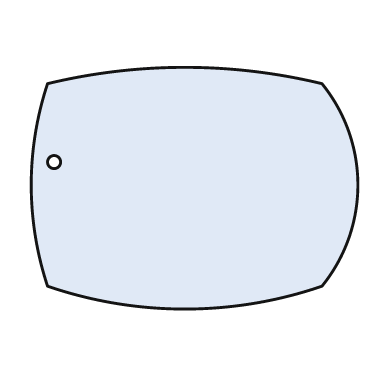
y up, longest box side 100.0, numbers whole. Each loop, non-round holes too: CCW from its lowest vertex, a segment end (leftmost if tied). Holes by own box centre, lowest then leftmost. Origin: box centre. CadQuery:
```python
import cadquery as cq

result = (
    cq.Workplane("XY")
    .moveTo(-45.0, -30.0)
    .threePointArc((-3.0, -37.0), (39.0, -30.0))
    .threePointArc((50.0, 1.0), (39.0, 32.0))
    .threePointArc((-3.0, 37.0), (-45.0, 32.0))
    .threePointArc((-50.0, 1.0), (-45.0, -30.0))
    .close()
    .moveTo(-43.0, 8.0)
    .circle(2.0)
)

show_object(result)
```